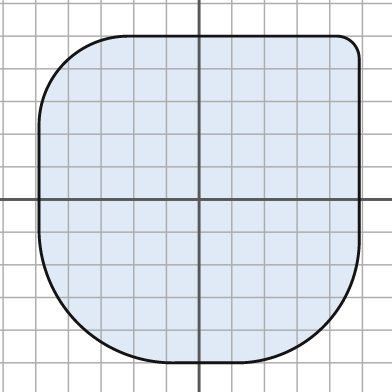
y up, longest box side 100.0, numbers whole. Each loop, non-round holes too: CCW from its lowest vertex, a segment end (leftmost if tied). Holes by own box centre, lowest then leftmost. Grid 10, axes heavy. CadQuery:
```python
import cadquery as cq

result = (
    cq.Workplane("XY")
    .moveTo(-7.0, -50.0)
    .lineTo(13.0, -50.0)
    .threePointArc((38.0, -39.0), (49.0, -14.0))
    .lineTo(49.0, 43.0)
    .threePointArc((47.0, 48.0), (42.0, 50.0))
    .lineTo(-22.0, 50.0)
    .threePointArc((-41.0, 42.0), (-49.0, 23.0))
    .lineTo(-49.0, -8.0)
    .threePointArc((-37.0, -38.0), (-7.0, -50.0))
    .close()
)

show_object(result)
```